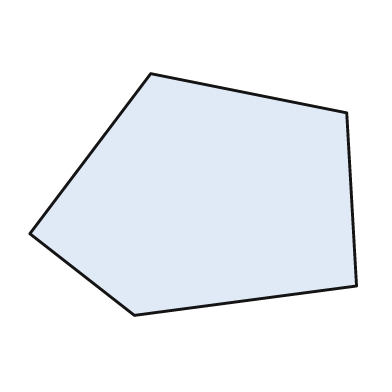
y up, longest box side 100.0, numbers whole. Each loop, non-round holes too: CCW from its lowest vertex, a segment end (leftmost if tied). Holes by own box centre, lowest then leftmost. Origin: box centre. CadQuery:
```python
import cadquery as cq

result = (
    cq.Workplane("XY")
    .moveTo(-18.0, -37.0)
    .lineTo(50.0, -28.0)
    .lineTo(47.0, 25.0)
    .lineTo(-13.0, 37.0)
    .lineTo(-50.0, -12.0)
    .close()
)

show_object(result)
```